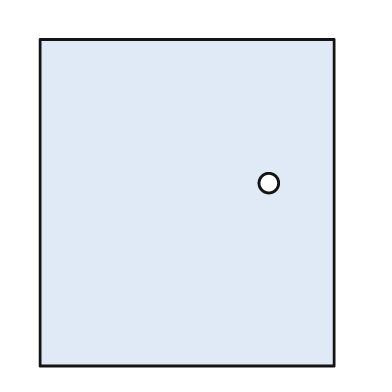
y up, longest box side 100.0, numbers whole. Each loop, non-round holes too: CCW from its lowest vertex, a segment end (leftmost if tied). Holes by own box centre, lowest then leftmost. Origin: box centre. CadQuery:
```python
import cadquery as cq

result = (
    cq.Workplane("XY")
    .moveTo(-45.0, -50.0)
    .lineTo(45.0, -50.0)
    .lineTo(45.0, 50.0)
    .lineTo(-45.0, 50.0)
    .close()
    .moveTo(25.0, 6.0)
    .circle(3.0)
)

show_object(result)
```